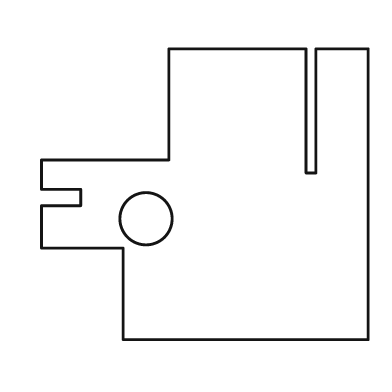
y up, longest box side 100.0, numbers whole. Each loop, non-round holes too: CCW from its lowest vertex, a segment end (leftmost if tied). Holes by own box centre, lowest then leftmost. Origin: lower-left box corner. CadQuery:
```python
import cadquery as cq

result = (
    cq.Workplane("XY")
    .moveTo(25.0, 0.0)
    .lineTo(100.0, 0.0)
    .lineTo(100.0, 89.0)
    .lineTo(84.0, 89.0)
    .lineTo(84.0, 51.0)
    .lineTo(81.0, 51.0)
    .lineTo(81.0, 89.0)
    .lineTo(39.0, 89.0)
    .lineTo(39.0, 55.0)
    .lineTo(0.0, 55.0)
    .lineTo(0.0, 46.0)
    .lineTo(12.0, 46.0)
    .lineTo(12.0, 41.0)
    .lineTo(0.0, 41.0)
    .lineTo(0.0, 28.0)
    .lineTo(25.0, 28.0)
    .close()
    .moveTo(32.0, 37.0)
    .circle(8.0)
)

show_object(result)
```